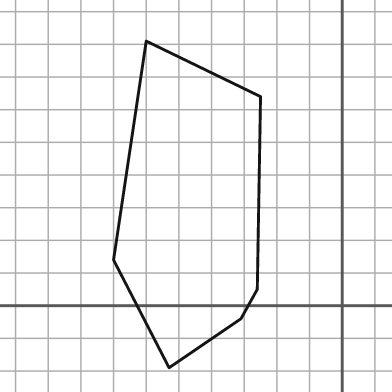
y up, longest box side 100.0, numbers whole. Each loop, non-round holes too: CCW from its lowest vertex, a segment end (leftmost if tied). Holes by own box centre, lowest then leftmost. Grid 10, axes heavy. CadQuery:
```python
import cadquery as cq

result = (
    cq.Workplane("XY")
    .moveTo(-53.0, -19.0)
    .lineTo(-31.0, -4.0)
    .lineTo(-26.0, 5.0)
    .lineTo(-25.0, 64.0)
    .lineTo(-60.0, 81.0)
    .lineTo(-70.0, 14.0)
    .close()
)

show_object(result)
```